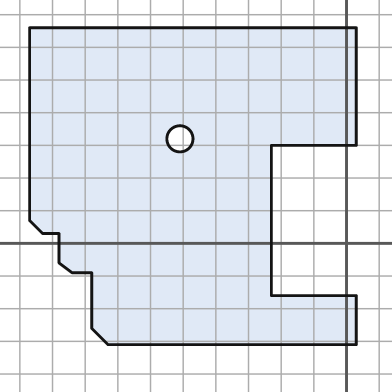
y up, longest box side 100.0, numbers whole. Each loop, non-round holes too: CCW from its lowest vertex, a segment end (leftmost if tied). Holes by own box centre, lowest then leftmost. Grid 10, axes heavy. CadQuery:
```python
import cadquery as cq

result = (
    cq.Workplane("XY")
    .moveTo(-73.0, -31.0)
    .lineTo(3.0, -31.0)
    .lineTo(3.0, -16.0)
    .lineTo(-23.0, -16.0)
    .lineTo(-23.0, 30.0)
    .lineTo(3.0, 30.0)
    .lineTo(3.0, 66.0)
    .lineTo(-97.0, 66.0)
    .lineTo(-97.0, 7.0)
    .lineTo(-93.0, 3.0)
    .lineTo(-88.0, 3.0)
    .lineTo(-88.0, -6.0)
    .lineTo(-84.0, -9.0)
    .lineTo(-78.0, -9.0)
    .lineTo(-78.0, -26.0)
    .close()
    .moveTo(-51.0, 32.0)
    .circle(4.0)
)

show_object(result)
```